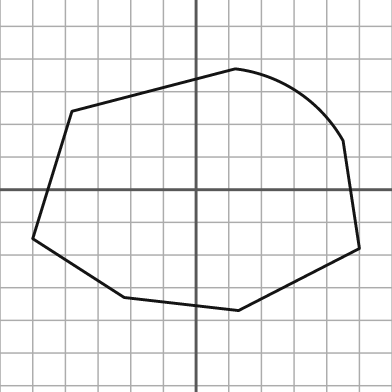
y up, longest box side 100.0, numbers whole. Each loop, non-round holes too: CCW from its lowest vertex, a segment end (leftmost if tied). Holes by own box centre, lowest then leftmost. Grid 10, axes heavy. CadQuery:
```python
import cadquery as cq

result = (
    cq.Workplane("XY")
    .moveTo(13.0, -37.0)
    .lineTo(50.0, -18.0)
    .lineTo(45.0, 15.0)
    .threePointArc((31.0, 30.0), (12.0, 37.0))
    .lineTo(-38.0, 24.0)
    .lineTo(-50.0, -15.0)
    .lineTo(-22.0, -33.0)
    .close()
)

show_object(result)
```